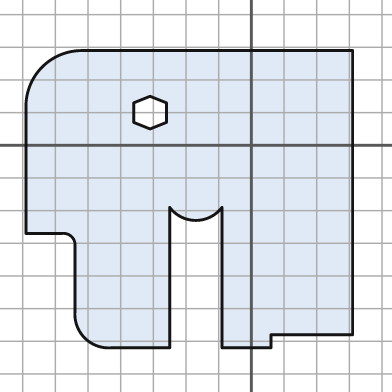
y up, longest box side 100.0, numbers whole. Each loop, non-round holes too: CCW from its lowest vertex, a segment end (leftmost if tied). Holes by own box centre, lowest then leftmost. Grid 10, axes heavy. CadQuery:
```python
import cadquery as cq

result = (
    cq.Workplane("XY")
    .moveTo(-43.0, -62.0)
    .lineTo(-25.0, -62.0)
    .lineTo(-25.0, -19.0)
    .threePointArc((-17.0, -23.0), (-9.0, -19.0))
    .lineTo(-9.0, -62.0)
    .lineTo(6.0, -62.0)
    .lineTo(6.0, -58.0)
    .lineTo(31.0, -58.0)
    .lineTo(31.0, 29.0)
    .lineTo(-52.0, 29.0)
    .threePointArc((-64.0, 24.0), (-69.0, 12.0))
    .lineTo(-69.0, -27.0)
    .lineTo(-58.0, -27.0)
    .threePointArc((-55.0, -28.0), (-54.0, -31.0))
    .lineTo(-54.0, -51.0)
    .threePointArc((-51.0, -59.0), (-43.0, -62.0))
    .close()
    .moveTo(-31.0, 5.0)
    .lineTo(-26.0, 7.0)
    .lineTo(-26.0, 13.0)
    .lineTo(-31.0, 15.0)
    .lineTo(-36.0, 13.0)
    .lineTo(-36.0, 7.0)
    .close()
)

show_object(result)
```